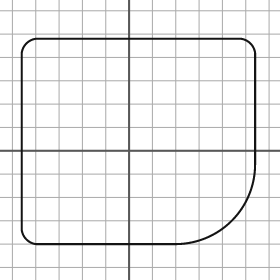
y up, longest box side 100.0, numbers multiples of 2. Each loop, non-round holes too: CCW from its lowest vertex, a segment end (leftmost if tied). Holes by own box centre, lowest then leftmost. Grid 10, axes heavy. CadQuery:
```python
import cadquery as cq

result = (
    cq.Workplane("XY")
    .moveTo(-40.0, -40.0)
    .lineTo(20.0, -40.0)
    .threePointArc((44.0, -30.0), (54.0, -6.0))
    .lineTo(54.0, 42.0)
    .threePointArc((52.0, 46.0), (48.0, 48.0))
    .lineTo(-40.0, 48.0)
    .threePointArc((-44.0, 46.0), (-46.0, 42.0))
    .lineTo(-46.0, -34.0)
    .threePointArc((-44.0, -38.0), (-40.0, -40.0))
    .close()
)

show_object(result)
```